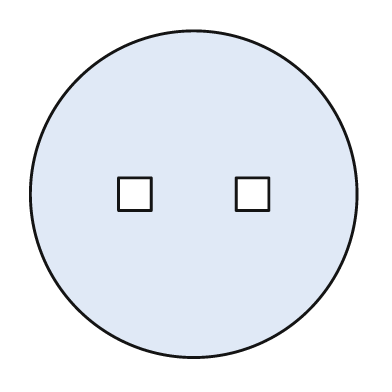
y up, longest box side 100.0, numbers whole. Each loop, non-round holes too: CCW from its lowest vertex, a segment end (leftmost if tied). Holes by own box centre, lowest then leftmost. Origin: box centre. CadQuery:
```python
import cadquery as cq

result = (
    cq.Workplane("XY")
    .moveTo(0.0, 0.0)
    .circle(50.0)
    .moveTo(-23.0, -5.0)
    .lineTo(-13.0, -5.0)
    .lineTo(-13.0, 5.0)
    .lineTo(-23.0, 5.0)
    .close()
    .moveTo(13.0, -5.0)
    .lineTo(23.0, -5.0)
    .lineTo(23.0, 5.0)
    .lineTo(13.0, 5.0)
    .close()
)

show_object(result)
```